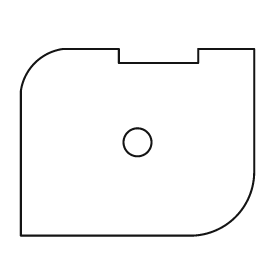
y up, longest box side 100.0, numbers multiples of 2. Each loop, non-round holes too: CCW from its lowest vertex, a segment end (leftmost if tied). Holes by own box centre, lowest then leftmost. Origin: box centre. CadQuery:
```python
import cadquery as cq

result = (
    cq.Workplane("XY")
    .moveTo(-50.0, -40.0)
    .lineTo(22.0, -40.0)
    .threePointArc((42.0, -32.0), (50.0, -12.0))
    .lineTo(50.0, 40.0)
    .lineTo(26.0, 40.0)
    .lineTo(26.0, 34.0)
    .lineTo(-8.0, 34.0)
    .lineTo(-8.0, 40.0)
    .lineTo(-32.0, 40.0)
    .threePointArc((-44.0, 34.0), (-50.0, 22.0))
    .close()
    .moveTo(0.0, 0.0)
    .circle(6.0)
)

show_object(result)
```